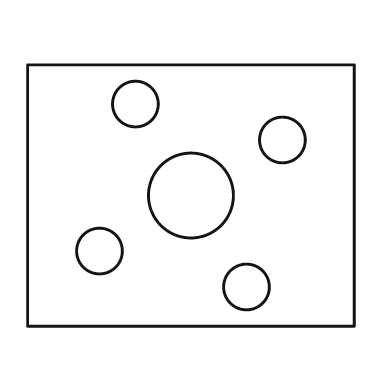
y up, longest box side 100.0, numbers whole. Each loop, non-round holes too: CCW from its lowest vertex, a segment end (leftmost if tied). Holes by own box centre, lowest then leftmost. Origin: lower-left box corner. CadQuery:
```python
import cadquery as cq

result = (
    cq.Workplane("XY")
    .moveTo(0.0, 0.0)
    .lineTo(100.0, 0.0)
    .lineTo(100.0, 80.0)
    .lineTo(0.0, 80.0)
    .close()
    .moveTo(67.0, 12.0)
    .circle(7.0)
    .moveTo(22.0, 23.0)
    .circle(7.0)
    .moveTo(50.0, 40.0)
    .circle(13.0)
    .moveTo(78.0, 57.0)
    .circle(7.0)
    .moveTo(33.0, 68.0)
    .circle(7.0)
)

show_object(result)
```